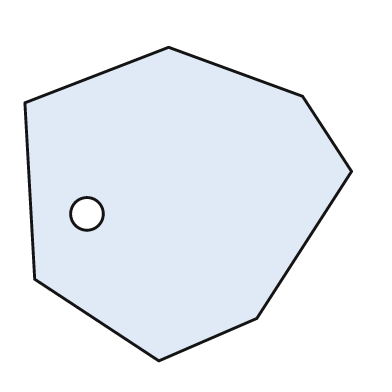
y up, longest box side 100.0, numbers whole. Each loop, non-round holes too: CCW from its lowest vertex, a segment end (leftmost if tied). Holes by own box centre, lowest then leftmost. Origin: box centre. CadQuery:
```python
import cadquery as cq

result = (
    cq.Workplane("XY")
    .moveTo(-9.0, -48.0)
    .lineTo(21.0, -35.0)
    .lineTo(50.0, 10.0)
    .lineTo(35.0, 33.0)
    .lineTo(-6.0, 48.0)
    .lineTo(-50.0, 31.0)
    .lineTo(-47.0, -23.0)
    .close()
    .moveTo(-31.0, -3.0)
    .circle(5.0)
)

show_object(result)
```